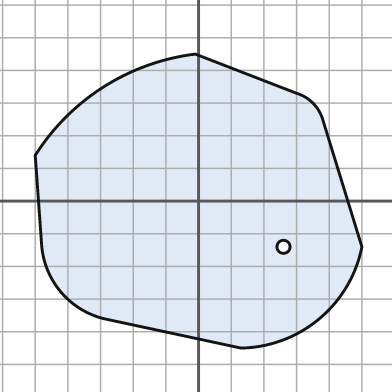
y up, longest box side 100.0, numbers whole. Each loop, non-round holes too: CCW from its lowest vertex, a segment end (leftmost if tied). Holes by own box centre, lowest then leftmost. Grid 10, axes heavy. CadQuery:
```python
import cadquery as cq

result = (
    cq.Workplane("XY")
    .moveTo(13.0, -45.0)
    .threePointArc((37.0, -36.0), (50.0, -14.0))
    .lineTo(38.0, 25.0)
    .threePointArc((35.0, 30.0), (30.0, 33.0))
    .lineTo(-1.0, 45.0)
    .threePointArc((-29.0, 35.0), (-50.0, 14.0))
    .lineTo(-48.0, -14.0)
    .threePointArc((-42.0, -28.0), (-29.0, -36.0))
    .close()
    .moveTo(26.0, -14.0)
    .circle(2.0)
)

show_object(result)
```